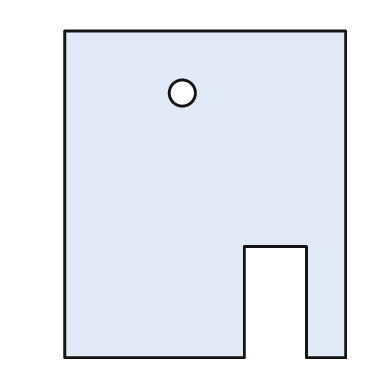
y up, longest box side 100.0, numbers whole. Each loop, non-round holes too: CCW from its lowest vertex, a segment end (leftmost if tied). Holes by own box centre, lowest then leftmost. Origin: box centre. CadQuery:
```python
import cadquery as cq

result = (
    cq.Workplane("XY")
    .moveTo(-43.0, -50.0)
    .lineTo(12.0, -50.0)
    .lineTo(12.0, -16.0)
    .lineTo(31.0, -16.0)
    .lineTo(31.0, -50.0)
    .lineTo(43.0, -50.0)
    .lineTo(43.0, 50.0)
    .lineTo(-43.0, 50.0)
    .close()
    .moveTo(-7.0, 31.0)
    .circle(4.0)
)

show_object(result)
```